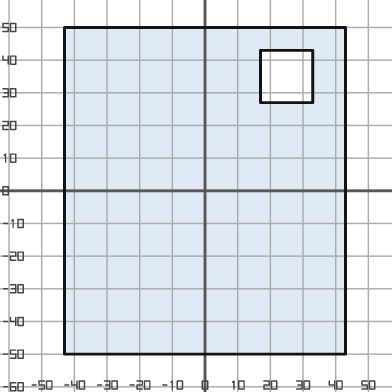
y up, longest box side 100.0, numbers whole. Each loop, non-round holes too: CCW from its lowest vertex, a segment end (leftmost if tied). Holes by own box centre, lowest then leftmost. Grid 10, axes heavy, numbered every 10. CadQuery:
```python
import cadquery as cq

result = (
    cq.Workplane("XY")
    .moveTo(-43.0, -50.0)
    .lineTo(43.0, -50.0)
    .lineTo(43.0, 50.0)
    .lineTo(-43.0, 50.0)
    .close()
    .moveTo(17.0, 27.0)
    .lineTo(33.0, 27.0)
    .lineTo(33.0, 43.0)
    .lineTo(17.0, 43.0)
    .close()
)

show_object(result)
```